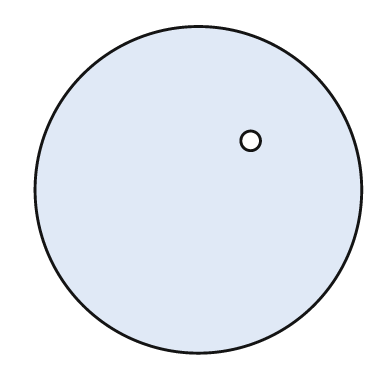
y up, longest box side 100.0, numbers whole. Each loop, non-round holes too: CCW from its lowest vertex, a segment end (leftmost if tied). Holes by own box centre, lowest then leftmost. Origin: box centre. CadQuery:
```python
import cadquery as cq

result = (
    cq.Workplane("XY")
    .moveTo(0.0, 0.0)
    .circle(50.0)
    .moveTo(16.0, 15.0)
    .circle(3.0)
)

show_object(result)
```